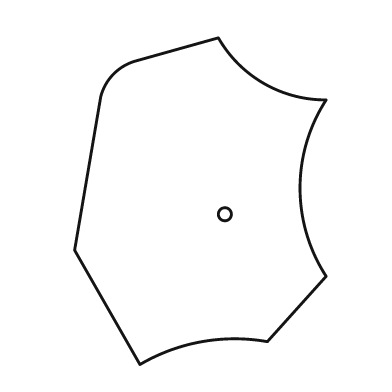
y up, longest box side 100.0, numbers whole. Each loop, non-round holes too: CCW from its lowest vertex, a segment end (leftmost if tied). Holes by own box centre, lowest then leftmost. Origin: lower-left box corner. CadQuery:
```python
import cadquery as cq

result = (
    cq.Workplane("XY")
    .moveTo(20.0, 0.0)
    .threePointArc((39.0, 7.0), (59.0, 7.0))
    .lineTo(77.0, 27.0)
    .threePointArc((69.0, 54.0), (77.0, 81.0))
    .threePointArc((58.0, 86.0), (44.0, 100.0))
    .lineTo(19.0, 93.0)
    .threePointArc((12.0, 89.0), (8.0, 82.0))
    .lineTo(0.0, 35.0)
    .close()
    .moveTo(46.0, 46.0)
    .circle(2.0)
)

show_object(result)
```